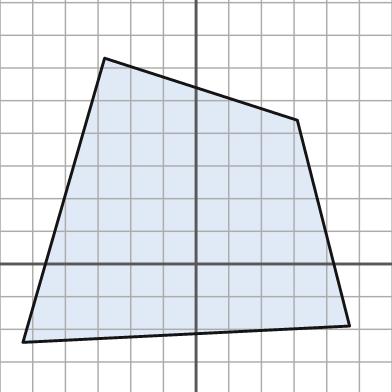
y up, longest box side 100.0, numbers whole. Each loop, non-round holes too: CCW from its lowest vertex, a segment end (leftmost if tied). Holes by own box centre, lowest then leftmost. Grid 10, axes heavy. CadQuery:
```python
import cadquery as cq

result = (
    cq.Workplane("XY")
    .moveTo(-53.0, -24.0)
    .lineTo(47.0, -19.0)
    .lineTo(31.0, 44.0)
    .lineTo(-28.0, 63.0)
    .close()
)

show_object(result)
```